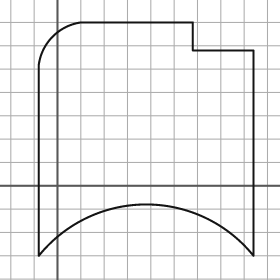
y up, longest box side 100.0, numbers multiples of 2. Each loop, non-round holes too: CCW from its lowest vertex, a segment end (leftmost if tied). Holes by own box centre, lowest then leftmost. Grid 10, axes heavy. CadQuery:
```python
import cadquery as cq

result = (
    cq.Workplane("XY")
    .moveTo(-8.0, -30.0)
    .threePointArc((38.0, -8.0), (84.0, -30.0))
    .lineTo(84.0, 58.0)
    .lineTo(58.0, 58.0)
    .lineTo(58.0, 70.0)
    .lineTo(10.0, 70.0)
    .threePointArc((-2.0, 64.0), (-8.0, 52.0))
    .close()
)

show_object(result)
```